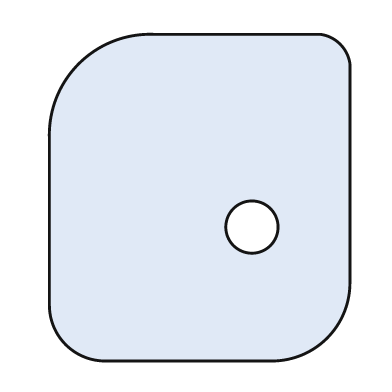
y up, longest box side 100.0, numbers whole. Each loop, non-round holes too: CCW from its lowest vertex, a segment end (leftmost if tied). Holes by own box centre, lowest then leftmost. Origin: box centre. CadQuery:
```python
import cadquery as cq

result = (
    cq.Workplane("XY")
    .moveTo(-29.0, -50.0)
    .lineTo(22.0, -50.0)
    .threePointArc((39.0, -43.0), (46.0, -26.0))
    .lineTo(46.0, 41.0)
    .threePointArc((43.0, 47.0), (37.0, 50.0))
    .lineTo(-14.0, 50.0)
    .threePointArc((-37.0, 41.0), (-46.0, 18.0))
    .lineTo(-46.0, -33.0)
    .threePointArc((-41.0, -45.0), (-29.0, -50.0))
    .close()
    .moveTo(16.0, -9.0)
    .circle(8.0)
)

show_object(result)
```